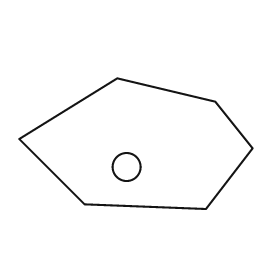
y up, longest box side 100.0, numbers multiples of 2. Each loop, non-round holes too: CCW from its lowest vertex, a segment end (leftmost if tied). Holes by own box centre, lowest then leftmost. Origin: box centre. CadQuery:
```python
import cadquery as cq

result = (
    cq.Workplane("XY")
    .moveTo(30.0, -28.0)
    .lineTo(50.0, -2.0)
    .lineTo(34.0, 18.0)
    .lineTo(-8.0, 28.0)
    .lineTo(-50.0, 2.0)
    .lineTo(-22.0, -26.0)
    .close()
    .moveTo(-4.0, -10.0)
    .circle(6.0)
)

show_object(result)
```